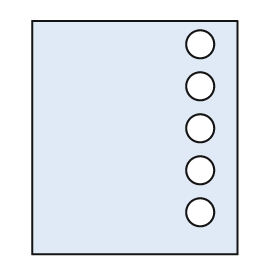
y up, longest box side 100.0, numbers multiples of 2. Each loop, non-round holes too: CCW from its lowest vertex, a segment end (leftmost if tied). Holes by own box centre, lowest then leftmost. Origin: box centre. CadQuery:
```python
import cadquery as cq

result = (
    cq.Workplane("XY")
    .moveTo(-44.0, -50.0)
    .lineTo(44.0, -50.0)
    .lineTo(44.0, 50.0)
    .lineTo(-44.0, 50.0)
    .close()
    .moveTo(28.0, -32.0)
    .circle(6.0)
    .moveTo(28.0, -14.0)
    .circle(6.0)
    .moveTo(28.0, 4.0)
    .circle(6.0)
    .moveTo(28.0, 22.0)
    .circle(6.0)
    .moveTo(28.0, 40.0)
    .circle(6.0)
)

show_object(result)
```